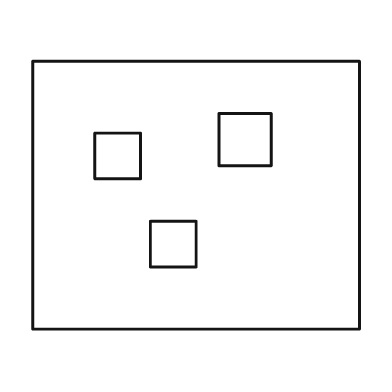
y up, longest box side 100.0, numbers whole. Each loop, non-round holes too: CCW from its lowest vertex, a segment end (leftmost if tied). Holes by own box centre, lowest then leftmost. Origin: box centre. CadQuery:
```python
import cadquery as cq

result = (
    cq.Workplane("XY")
    .moveTo(-50.0, -41.0)
    .lineTo(50.0, -41.0)
    .lineTo(50.0, 41.0)
    .lineTo(-50.0, 41.0)
    .close()
    .moveTo(-14.0, -22.0)
    .lineTo(0.0, -22.0)
    .lineTo(0.0, -8.0)
    .lineTo(-14.0, -8.0)
    .close()
    .moveTo(-31.0, 5.0)
    .lineTo(-17.0, 5.0)
    .lineTo(-17.0, 19.0)
    .lineTo(-31.0, 19.0)
    .close()
    .moveTo(7.0, 9.0)
    .lineTo(23.0, 9.0)
    .lineTo(23.0, 25.0)
    .lineTo(7.0, 25.0)
    .close()
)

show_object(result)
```